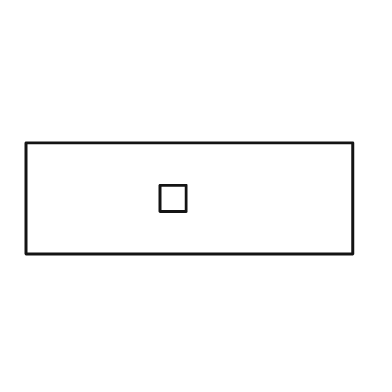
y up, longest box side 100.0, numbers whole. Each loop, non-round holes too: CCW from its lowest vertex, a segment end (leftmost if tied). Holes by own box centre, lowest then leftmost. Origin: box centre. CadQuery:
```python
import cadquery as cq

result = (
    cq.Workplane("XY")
    .moveTo(-50.0, -17.0)
    .lineTo(50.0, -17.0)
    .lineTo(50.0, 17.0)
    .lineTo(-50.0, 17.0)
    .close()
    .moveTo(-9.0, -4.0)
    .lineTo(-1.0, -4.0)
    .lineTo(-1.0, 4.0)
    .lineTo(-9.0, 4.0)
    .close()
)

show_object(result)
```